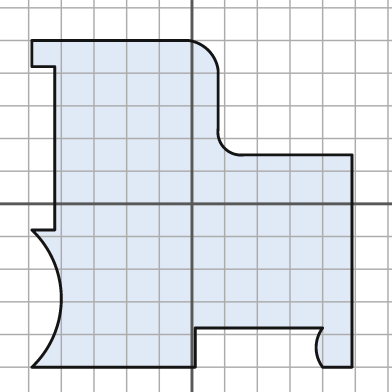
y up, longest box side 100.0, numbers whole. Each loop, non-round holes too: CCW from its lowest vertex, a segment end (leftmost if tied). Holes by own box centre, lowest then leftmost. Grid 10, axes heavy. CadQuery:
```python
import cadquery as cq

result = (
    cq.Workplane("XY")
    .moveTo(-49.0, -50.0)
    .lineTo(1.0, -50.0)
    .lineTo(1.0, -38.0)
    .lineTo(40.0, -38.0)
    .threePointArc((38.0, -44.0), (40.0, -50.0))
    .lineTo(49.0, -50.0)
    .lineTo(49.0, 15.0)
    .lineTo(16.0, 15.0)
    .threePointArc((10.0, 17.0), (8.0, 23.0))
    .lineTo(8.0, 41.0)
    .threePointArc((5.0, 47.0), (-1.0, 50.0))
    .lineTo(-49.0, 50.0)
    .lineTo(-49.0, 42.0)
    .lineTo(-42.0, 42.0)
    .lineTo(-42.0, -8.0)
    .lineTo(-49.0, -8.0)
    .threePointArc((-40.0, -29.0), (-49.0, -50.0))
    .close()
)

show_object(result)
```